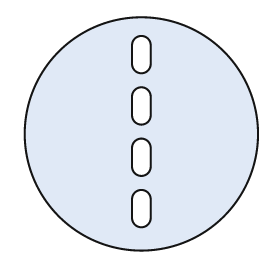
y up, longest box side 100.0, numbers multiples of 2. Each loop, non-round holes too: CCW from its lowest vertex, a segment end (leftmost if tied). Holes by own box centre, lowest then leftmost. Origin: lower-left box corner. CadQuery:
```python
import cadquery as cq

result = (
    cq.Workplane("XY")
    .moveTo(50.0, 50.0)
    .circle(50.0)
    .moveTo(46.0, 14.0)
    .threePointArc((50.0, 10.0), (54.0, 14.0))
    .lineTo(54.0, 22.0)
    .threePointArc((50.0, 26.0), (46.0, 22.0))
    .close()
    .moveTo(46.0, 36.0)
    .threePointArc((50.0, 32.0), (54.0, 36.0))
    .lineTo(54.0, 44.0)
    .threePointArc((50.0, 48.0), (46.0, 44.0))
    .close()
    .moveTo(46.0, 58.0)
    .threePointArc((50.0, 54.0), (54.0, 58.0))
    .lineTo(54.0, 66.0)
    .threePointArc((50.0, 70.0), (46.0, 66.0))
    .close()
    .moveTo(46.0, 80.0)
    .threePointArc((50.0, 76.0), (54.0, 80.0))
    .lineTo(54.0, 88.0)
    .threePointArc((50.0, 92.0), (46.0, 88.0))
    .close()
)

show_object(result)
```